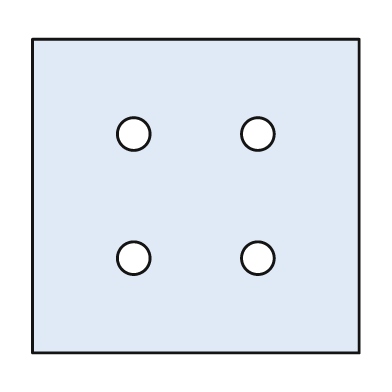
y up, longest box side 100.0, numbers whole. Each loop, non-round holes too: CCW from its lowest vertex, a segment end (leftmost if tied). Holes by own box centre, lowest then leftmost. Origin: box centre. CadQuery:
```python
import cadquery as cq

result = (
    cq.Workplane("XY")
    .moveTo(-50.0, -48.0)
    .lineTo(50.0, -48.0)
    .lineTo(50.0, 48.0)
    .lineTo(-50.0, 48.0)
    .close()
    .moveTo(-19.0, -19.0)
    .circle(5.0)
    .moveTo(19.0, -19.0)
    .circle(5.0)
    .moveTo(-19.0, 19.0)
    .circle(5.0)
    .moveTo(19.0, 19.0)
    .circle(5.0)
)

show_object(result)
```